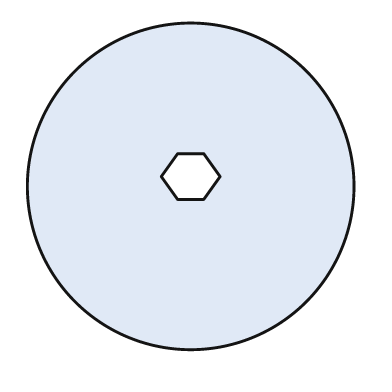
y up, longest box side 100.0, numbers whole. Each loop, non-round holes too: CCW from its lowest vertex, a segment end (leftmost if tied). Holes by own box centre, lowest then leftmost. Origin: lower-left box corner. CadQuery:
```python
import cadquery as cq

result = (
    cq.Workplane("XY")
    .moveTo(50.0, 50.0)
    .circle(50.0)
    .moveTo(46.0, 46.0)
    .lineTo(54.0, 46.0)
    .lineTo(59.0, 53.0)
    .lineTo(54.0, 60.0)
    .lineTo(46.0, 60.0)
    .lineTo(41.0, 53.0)
    .close()
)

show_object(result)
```